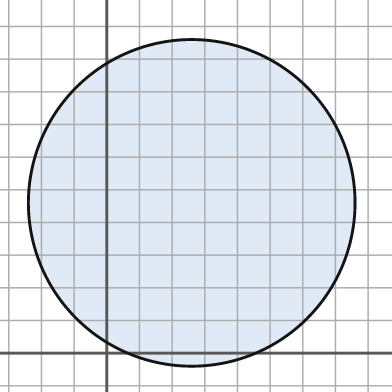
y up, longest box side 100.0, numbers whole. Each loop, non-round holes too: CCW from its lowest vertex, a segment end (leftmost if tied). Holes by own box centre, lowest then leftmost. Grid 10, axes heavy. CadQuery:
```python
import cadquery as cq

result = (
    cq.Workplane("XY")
    .moveTo(26.0, 46.0)
    .circle(50.0)
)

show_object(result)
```